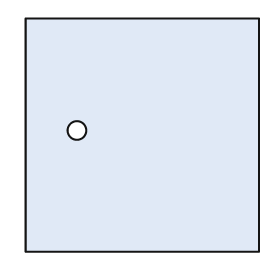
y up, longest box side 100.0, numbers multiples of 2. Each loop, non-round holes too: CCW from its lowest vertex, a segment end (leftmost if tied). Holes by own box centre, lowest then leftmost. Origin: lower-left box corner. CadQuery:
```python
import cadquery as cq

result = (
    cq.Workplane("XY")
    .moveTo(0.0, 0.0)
    .lineTo(100.0, 0.0)
    .lineTo(100.0, 100.0)
    .lineTo(0.0, 100.0)
    .close()
    .moveTo(22.0, 52.0)
    .circle(4.0)
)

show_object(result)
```